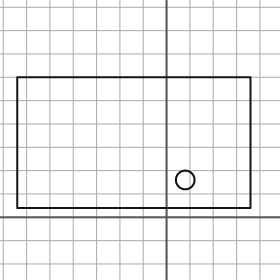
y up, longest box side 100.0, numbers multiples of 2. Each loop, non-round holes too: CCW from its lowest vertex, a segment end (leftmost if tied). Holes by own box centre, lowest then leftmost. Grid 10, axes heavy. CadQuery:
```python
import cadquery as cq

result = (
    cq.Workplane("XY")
    .moveTo(-64.0, 4.0)
    .lineTo(36.0, 4.0)
    .lineTo(36.0, 60.0)
    .lineTo(-64.0, 60.0)
    .close()
    .moveTo(8.0, 16.0)
    .circle(4.0)
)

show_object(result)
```